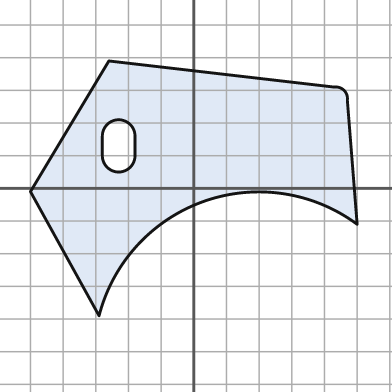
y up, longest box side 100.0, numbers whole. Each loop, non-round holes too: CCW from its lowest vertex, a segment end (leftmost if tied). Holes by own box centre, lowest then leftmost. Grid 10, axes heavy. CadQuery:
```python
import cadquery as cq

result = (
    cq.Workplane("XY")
    .moveTo(-29.0, -39.0)
    .threePointArc((3.0, -4.0), (50.0, -11.0))
    .lineTo(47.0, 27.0)
    .threePointArc((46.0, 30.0), (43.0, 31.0))
    .lineTo(-26.0, 39.0)
    .lineTo(-50.0, -1.0)
    .close()
    .moveTo(-28.0, 10.0)
    .threePointArc((-23.0, 5.0), (-18.0, 10.0))
    .lineTo(-18.0, 16.0)
    .threePointArc((-23.0, 21.0), (-28.0, 16.0))
    .close()
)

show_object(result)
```